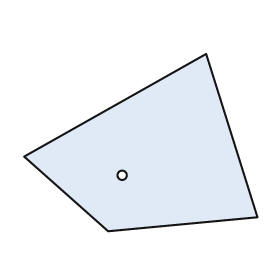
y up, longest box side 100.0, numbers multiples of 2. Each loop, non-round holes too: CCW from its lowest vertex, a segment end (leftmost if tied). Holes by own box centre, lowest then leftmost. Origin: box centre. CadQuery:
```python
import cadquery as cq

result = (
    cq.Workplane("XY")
    .moveTo(-14.0, -38.0)
    .lineTo(50.0, -32.0)
    .lineTo(28.0, 38.0)
    .lineTo(-50.0, -6.0)
    .close()
    .moveTo(-8.0, -14.0)
    .circle(2.0)
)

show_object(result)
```